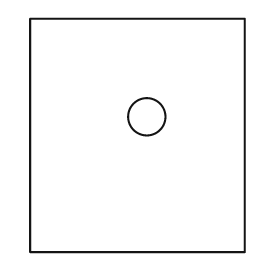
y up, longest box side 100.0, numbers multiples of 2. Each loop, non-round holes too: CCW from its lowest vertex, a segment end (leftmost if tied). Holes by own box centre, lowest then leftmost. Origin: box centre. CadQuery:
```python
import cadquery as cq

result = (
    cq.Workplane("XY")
    .moveTo(-46.0, -50.0)
    .lineTo(46.0, -50.0)
    .lineTo(46.0, 50.0)
    .lineTo(-46.0, 50.0)
    .close()
    .moveTo(4.0, 8.0)
    .circle(8.0)
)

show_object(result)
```